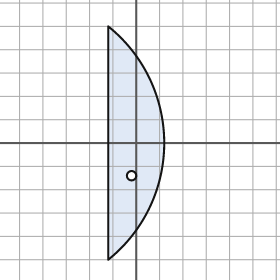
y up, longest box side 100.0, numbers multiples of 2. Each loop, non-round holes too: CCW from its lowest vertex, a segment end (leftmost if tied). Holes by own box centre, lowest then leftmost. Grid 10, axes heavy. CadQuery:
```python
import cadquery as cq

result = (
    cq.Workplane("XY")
    .moveTo(-12.0, -50.0)
    .threePointArc((12.0, 0.0), (-12.0, 50.0))
    .close()
    .moveTo(-2.0, -14.0)
    .circle(2.0)
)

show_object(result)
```